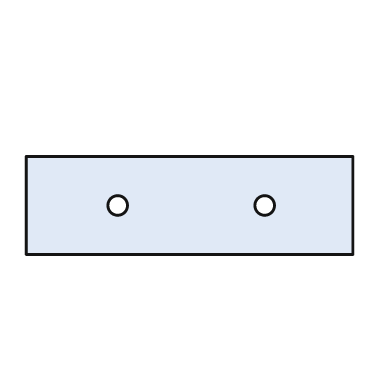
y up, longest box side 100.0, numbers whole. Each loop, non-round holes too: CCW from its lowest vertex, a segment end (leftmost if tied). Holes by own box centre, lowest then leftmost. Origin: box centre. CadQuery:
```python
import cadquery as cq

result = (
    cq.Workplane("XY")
    .moveTo(-50.0, -15.0)
    .lineTo(50.0, -15.0)
    .lineTo(50.0, 15.0)
    .lineTo(-50.0, 15.0)
    .close()
    .moveTo(-22.0, 0.0)
    .circle(3.0)
    .moveTo(23.0, 0.0)
    .circle(3.0)
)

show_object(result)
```